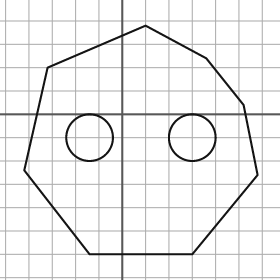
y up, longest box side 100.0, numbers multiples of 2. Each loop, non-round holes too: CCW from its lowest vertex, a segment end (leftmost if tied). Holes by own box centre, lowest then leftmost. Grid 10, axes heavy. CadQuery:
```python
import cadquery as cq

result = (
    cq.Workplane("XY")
    .moveTo(-14.0, -60.0)
    .lineTo(30.0, -60.0)
    .lineTo(58.0, -26.0)
    .lineTo(52.0, 4.0)
    .lineTo(36.0, 24.0)
    .lineTo(10.0, 38.0)
    .lineTo(-32.0, 20.0)
    .lineTo(-42.0, -24.0)
    .close()
    .moveTo(-14.0, -10.0)
    .circle(10.0)
    .moveTo(30.0, -10.0)
    .circle(10.0)
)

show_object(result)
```